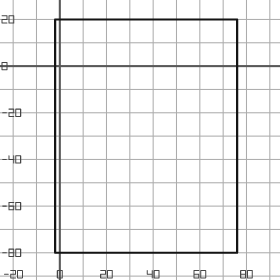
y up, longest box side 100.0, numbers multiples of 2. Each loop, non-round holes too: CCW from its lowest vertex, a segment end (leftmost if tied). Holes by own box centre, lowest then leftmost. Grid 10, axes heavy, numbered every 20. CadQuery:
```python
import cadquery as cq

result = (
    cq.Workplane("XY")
    .moveTo(-2.0, -80.0)
    .lineTo(76.0, -80.0)
    .lineTo(76.0, 20.0)
    .lineTo(-2.0, 20.0)
    .close()
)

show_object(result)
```